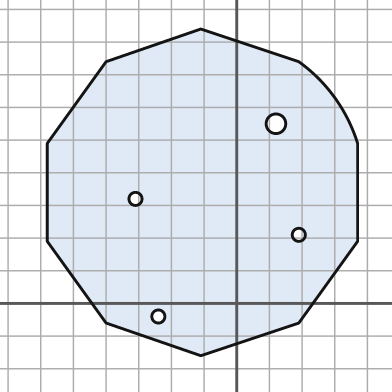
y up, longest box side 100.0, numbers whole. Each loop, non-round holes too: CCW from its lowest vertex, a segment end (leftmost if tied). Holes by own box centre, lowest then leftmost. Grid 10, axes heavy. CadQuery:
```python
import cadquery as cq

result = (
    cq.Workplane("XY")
    .moveTo(-11.0, -16.0)
    .lineTo(19.0, -6.0)
    .lineTo(37.0, 19.0)
    .lineTo(37.0, 49.0)
    .threePointArc((30.0, 63.0), (19.0, 74.0))
    .lineTo(-11.0, 84.0)
    .lineTo(-40.0, 74.0)
    .lineTo(-58.0, 49.0)
    .lineTo(-58.0, 19.0)
    .lineTo(-40.0, -6.0)
    .close()
    .moveTo(-24.0, -4.0)
    .circle(2.0)
    .moveTo(19.0, 21.0)
    .circle(2.0)
    .moveTo(-31.0, 32.0)
    .circle(2.0)
    .moveTo(12.0, 55.0)
    .circle(3.0)
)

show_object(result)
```